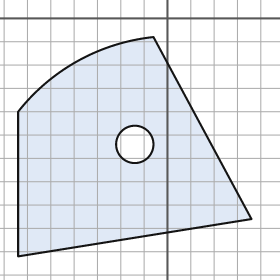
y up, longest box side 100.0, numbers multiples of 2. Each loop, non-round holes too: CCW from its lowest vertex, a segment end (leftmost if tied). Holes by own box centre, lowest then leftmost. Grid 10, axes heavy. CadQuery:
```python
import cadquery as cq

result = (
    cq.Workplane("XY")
    .moveTo(-64.0, -102.0)
    .lineTo(36.0, -86.0)
    .lineTo(-6.0, -8.0)
    .threePointArc((-38.0, -18.0), (-64.0, -40.0))
    .close()
    .moveTo(-14.0, -54.0)
    .circle(8.0)
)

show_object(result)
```